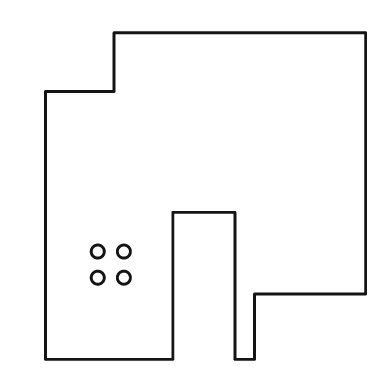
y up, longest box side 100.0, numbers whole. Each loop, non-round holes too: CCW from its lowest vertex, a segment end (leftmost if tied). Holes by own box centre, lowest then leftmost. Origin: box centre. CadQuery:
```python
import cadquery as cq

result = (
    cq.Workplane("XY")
    .moveTo(-49.0, -50.0)
    .lineTo(-10.0, -50.0)
    .lineTo(-10.0, -5.0)
    .lineTo(9.0, -5.0)
    .lineTo(9.0, -50.0)
    .lineTo(15.0, -50.0)
    .lineTo(15.0, -30.0)
    .lineTo(49.0, -30.0)
    .lineTo(49.0, 50.0)
    .lineTo(-28.0, 50.0)
    .lineTo(-28.0, 32.0)
    .lineTo(-49.0, 32.0)
    .close()
    .moveTo(-33.0, -25.0)
    .circle(2.0)
    .moveTo(-25.0, -25.0)
    .circle(2.0)
    .moveTo(-33.0, -17.0)
    .circle(2.0)
    .moveTo(-25.0, -17.0)
    .circle(2.0)
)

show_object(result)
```